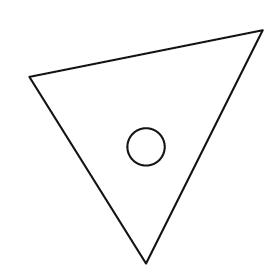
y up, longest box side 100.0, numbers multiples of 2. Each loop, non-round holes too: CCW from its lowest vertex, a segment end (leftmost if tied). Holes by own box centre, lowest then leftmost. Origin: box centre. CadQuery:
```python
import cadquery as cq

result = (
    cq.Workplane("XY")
    .moveTo(0.0, -50.0)
    .lineTo(50.0, 50.0)
    .lineTo(-50.0, 30.0)
    .close()
    .moveTo(0.0, 0.0)
    .circle(8.0)
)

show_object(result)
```